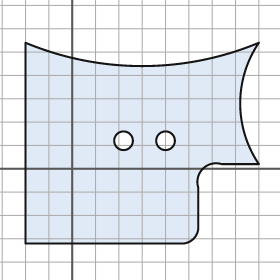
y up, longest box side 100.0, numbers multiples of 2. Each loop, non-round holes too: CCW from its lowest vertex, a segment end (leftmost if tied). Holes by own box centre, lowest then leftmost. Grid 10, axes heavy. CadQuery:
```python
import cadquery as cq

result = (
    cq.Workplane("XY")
    .moveTo(-20.0, -32.0)
    .lineTo(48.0, -32.0)
    .threePointArc((52.0, -30.0), (54.0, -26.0))
    .lineTo(54.0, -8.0)
    .threePointArc((56.0, 0.0), (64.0, 2.0))
    .lineTo(80.0, 2.0)
    .threePointArc((72.0, 28.0), (80.0, 54.0))
    .threePointArc((30.0, 44.0), (-20.0, 54.0))
    .close()
    .moveTo(22.0, 12.0)
    .circle(4.0)
    .moveTo(40.0, 12.0)
    .circle(4.0)
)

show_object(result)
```